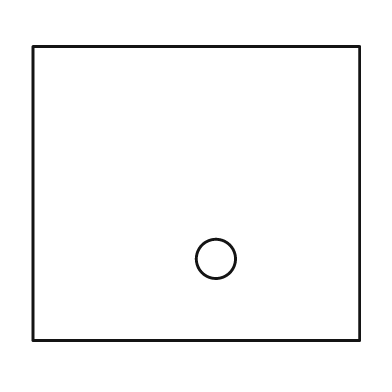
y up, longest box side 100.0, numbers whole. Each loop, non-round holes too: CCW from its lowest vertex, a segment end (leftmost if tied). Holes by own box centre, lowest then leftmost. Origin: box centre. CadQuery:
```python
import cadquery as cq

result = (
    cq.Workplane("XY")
    .moveTo(-50.0, -45.0)
    .lineTo(50.0, -45.0)
    .lineTo(50.0, 45.0)
    .lineTo(-50.0, 45.0)
    .close()
    .moveTo(6.0, -20.0)
    .circle(6.0)
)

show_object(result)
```